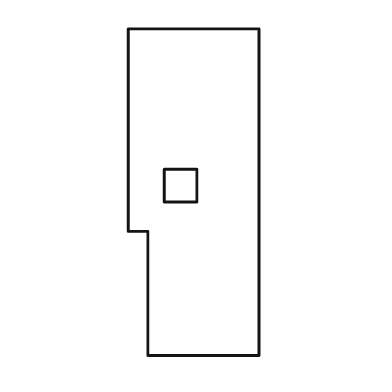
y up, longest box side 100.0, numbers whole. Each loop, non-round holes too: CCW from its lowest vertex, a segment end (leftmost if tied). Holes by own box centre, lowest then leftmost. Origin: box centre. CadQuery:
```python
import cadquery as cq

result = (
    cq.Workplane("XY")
    .moveTo(-14.0, -50.0)
    .lineTo(20.0, -50.0)
    .lineTo(20.0, 50.0)
    .lineTo(-20.0, 50.0)
    .lineTo(-20.0, -12.0)
    .lineTo(-14.0, -12.0)
    .close()
    .moveTo(-9.0, -3.0)
    .lineTo(1.0, -3.0)
    .lineTo(1.0, 7.0)
    .lineTo(-9.0, 7.0)
    .close()
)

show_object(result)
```